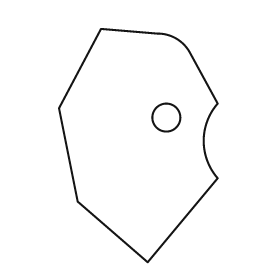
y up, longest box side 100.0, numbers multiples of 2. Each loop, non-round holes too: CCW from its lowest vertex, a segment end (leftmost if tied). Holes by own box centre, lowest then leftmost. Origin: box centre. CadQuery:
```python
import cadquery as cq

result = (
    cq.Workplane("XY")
    .moveTo(4.0, -50.0)
    .lineTo(34.0, -14.0)
    .threePointArc((28.0, 2.0), (34.0, 18.0))
    .lineTo(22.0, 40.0)
    .threePointArc((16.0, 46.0), (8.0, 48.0))
    .lineTo(-16.0, 50.0)
    .lineTo(-34.0, 16.0)
    .lineTo(-26.0, -24.0)
    .close()
    .moveTo(12.0, 12.0)
    .circle(6.0)
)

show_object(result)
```